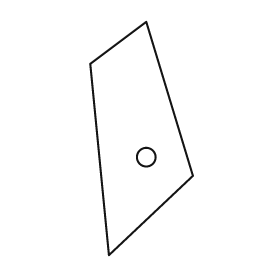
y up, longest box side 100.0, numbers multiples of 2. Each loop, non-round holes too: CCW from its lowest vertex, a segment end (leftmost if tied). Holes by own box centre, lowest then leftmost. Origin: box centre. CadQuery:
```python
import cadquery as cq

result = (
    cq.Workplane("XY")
    .moveTo(-14.0, -50.0)
    .lineTo(22.0, -16.0)
    .lineTo(2.0, 50.0)
    .lineTo(-22.0, 32.0)
    .close()
    .moveTo(2.0, -8.0)
    .circle(4.0)
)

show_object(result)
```